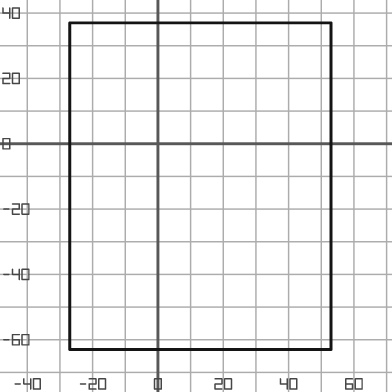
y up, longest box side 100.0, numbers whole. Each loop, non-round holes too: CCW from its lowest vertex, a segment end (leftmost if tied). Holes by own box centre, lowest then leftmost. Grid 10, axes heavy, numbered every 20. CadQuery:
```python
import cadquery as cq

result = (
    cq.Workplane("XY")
    .moveTo(-27.0, -63.0)
    .lineTo(53.0, -63.0)
    .lineTo(53.0, 37.0)
    .lineTo(-27.0, 37.0)
    .close()
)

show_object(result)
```